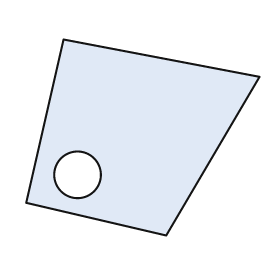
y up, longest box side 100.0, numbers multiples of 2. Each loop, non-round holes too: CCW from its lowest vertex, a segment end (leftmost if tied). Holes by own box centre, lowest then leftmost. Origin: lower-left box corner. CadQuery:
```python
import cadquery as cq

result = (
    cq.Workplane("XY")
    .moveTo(60.0, 0.0)
    .lineTo(100.0, 68.0)
    .lineTo(16.0, 84.0)
    .lineTo(0.0, 14.0)
    .close()
    .moveTo(22.0, 26.0)
    .circle(10.0)
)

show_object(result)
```